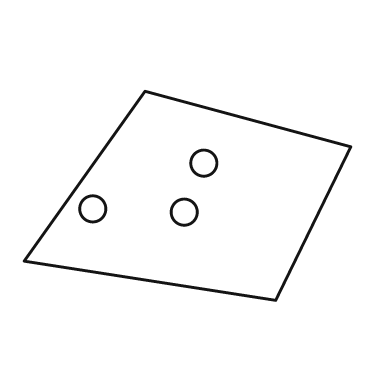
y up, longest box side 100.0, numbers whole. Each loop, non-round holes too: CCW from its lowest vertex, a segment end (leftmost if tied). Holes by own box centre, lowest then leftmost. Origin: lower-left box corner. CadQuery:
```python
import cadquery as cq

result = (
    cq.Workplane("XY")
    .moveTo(77.0, 0.0)
    .lineTo(100.0, 47.0)
    .lineTo(37.0, 64.0)
    .lineTo(0.0, 12.0)
    .close()
    .moveTo(49.0, 27.0)
    .circle(4.0)
    .moveTo(21.0, 28.0)
    .circle(4.0)
    .moveTo(55.0, 42.0)
    .circle(4.0)
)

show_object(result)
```